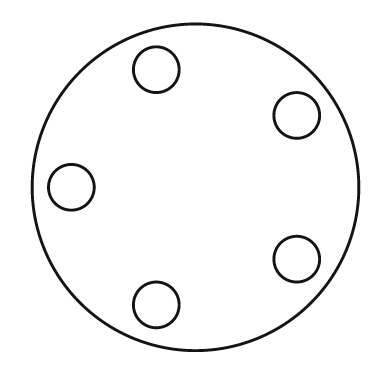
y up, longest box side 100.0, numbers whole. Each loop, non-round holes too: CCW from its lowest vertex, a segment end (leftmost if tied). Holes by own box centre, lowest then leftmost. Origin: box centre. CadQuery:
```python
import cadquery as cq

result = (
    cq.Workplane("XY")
    .moveTo(0.0, 0.0)
    .circle(50.0)
    .moveTo(-12.0, -36.0)
    .circle(7.0)
    .moveTo(31.0, -22.0)
    .circle(7.0)
    .moveTo(-38.0, 0.0)
    .circle(7.0)
    .moveTo(31.0, 22.0)
    .circle(7.0)
    .moveTo(-12.0, 36.0)
    .circle(7.0)
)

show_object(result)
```